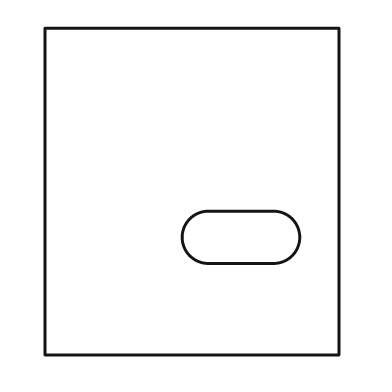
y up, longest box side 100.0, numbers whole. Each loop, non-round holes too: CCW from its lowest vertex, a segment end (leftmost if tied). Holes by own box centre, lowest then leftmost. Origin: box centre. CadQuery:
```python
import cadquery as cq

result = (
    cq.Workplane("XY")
    .moveTo(-45.0, -50.0)
    .lineTo(45.0, -50.0)
    .lineTo(45.0, 50.0)
    .lineTo(-45.0, 50.0)
    .close()
    .moveTo(5.0, -22.0)
    .lineTo(25.0, -22.0)
    .threePointArc((33.0, -14.0), (25.0, -6.0))
    .lineTo(5.0, -6.0)
    .threePointArc((-3.0, -14.0), (5.0, -22.0))
    .close()
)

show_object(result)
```